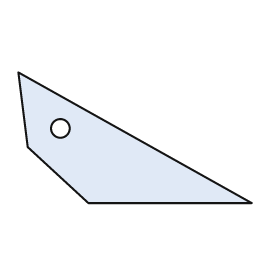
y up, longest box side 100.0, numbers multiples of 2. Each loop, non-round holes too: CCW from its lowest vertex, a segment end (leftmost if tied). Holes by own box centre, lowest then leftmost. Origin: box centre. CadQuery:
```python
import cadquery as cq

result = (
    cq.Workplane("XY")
    .moveTo(-20.0, -28.0)
    .lineTo(50.0, -28.0)
    .lineTo(-50.0, 28.0)
    .lineTo(-46.0, -4.0)
    .close()
    .moveTo(-32.0, 4.0)
    .circle(4.0)
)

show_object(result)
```